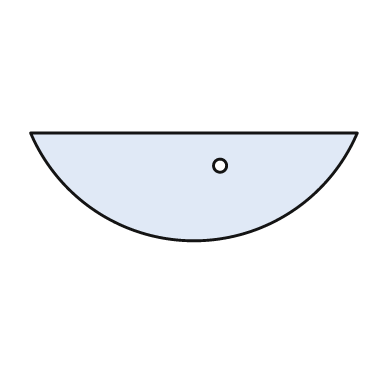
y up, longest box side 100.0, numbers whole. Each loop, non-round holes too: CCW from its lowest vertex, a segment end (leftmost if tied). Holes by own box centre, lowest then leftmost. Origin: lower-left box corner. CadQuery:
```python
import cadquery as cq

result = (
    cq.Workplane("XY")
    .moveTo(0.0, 33.0)
    .threePointArc((50.0, 0.0), (100.0, 33.0))
    .close()
    .moveTo(58.0, 23.0)
    .circle(2.0)
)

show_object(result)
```